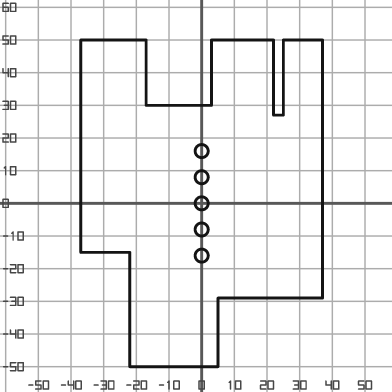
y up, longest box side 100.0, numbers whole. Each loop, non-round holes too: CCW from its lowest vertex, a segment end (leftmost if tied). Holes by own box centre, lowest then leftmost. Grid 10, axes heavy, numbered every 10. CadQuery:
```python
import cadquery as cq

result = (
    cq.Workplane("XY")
    .moveTo(-22.0, -50.0)
    .lineTo(5.0, -50.0)
    .lineTo(5.0, -29.0)
    .lineTo(37.0, -29.0)
    .lineTo(37.0, 50.0)
    .lineTo(25.0, 50.0)
    .lineTo(25.0, 27.0)
    .lineTo(22.0, 27.0)
    .lineTo(22.0, 50.0)
    .lineTo(3.0, 50.0)
    .lineTo(3.0, 30.0)
    .lineTo(-17.0, 30.0)
    .lineTo(-17.0, 50.0)
    .lineTo(-37.0, 50.0)
    .lineTo(-37.0, -15.0)
    .lineTo(-22.0, -15.0)
    .close()
    .moveTo(0.0, -16.0)
    .circle(2.0)
    .moveTo(0.0, -8.0)
    .circle(2.0)
    .moveTo(0.0, 0.0)
    .circle(2.0)
    .moveTo(0.0, 8.0)
    .circle(2.0)
    .moveTo(0.0, 16.0)
    .circle(2.0)
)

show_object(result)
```